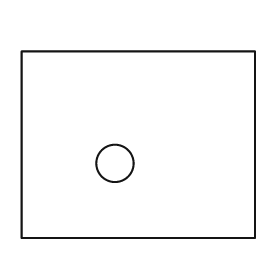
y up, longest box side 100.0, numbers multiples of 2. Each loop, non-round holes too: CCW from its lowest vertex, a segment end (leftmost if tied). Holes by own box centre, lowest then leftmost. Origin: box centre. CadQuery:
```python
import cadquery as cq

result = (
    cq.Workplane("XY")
    .moveTo(-50.0, -40.0)
    .lineTo(50.0, -40.0)
    .lineTo(50.0, 40.0)
    .lineTo(-50.0, 40.0)
    .close()
    .moveTo(-10.0, -8.0)
    .circle(8.0)
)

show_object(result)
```